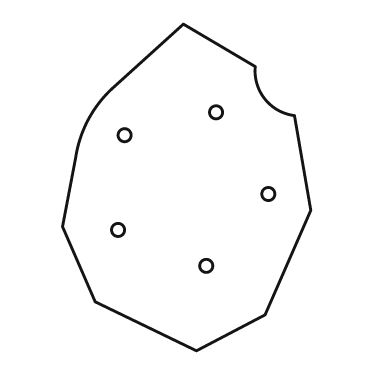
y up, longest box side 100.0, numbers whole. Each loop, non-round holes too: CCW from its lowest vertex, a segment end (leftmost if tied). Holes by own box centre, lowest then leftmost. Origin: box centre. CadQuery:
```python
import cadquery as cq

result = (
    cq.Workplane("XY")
    .moveTo(3.0, -50.0)
    .lineTo(24.0, -39.0)
    .lineTo(38.0, -7.0)
    .lineTo(33.0, 22.0)
    .threePointArc((24.0, 27.0), (21.0, 37.0))
    .lineTo(-1.0, 50.0)
    .lineTo(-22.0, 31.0)
    .threePointArc((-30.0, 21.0), (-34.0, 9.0))
    .lineTo(-38.0, -12.0)
    .lineTo(-28.0, -35.0)
    .close()
    .moveTo(6.0, -24.0)
    .circle(2.0)
    .moveTo(-21.0, -13.0)
    .circle(2.0)
    .moveTo(25.0, -2.0)
    .circle(2.0)
    .moveTo(-19.0, 16.0)
    .circle(2.0)
    .moveTo(9.0, 23.0)
    .circle(2.0)
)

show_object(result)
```